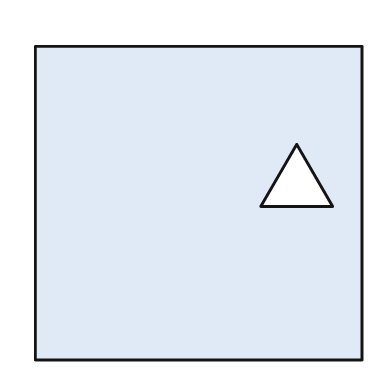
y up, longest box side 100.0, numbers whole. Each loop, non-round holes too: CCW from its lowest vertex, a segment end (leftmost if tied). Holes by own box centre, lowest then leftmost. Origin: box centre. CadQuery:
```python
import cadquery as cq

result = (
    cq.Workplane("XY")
    .moveTo(-50.0, -48.0)
    .lineTo(50.0, -48.0)
    .lineTo(50.0, 48.0)
    .lineTo(-50.0, 48.0)
    .close()
    .moveTo(19.0, -1.0)
    .lineTo(41.0, -1.0)
    .lineTo(30.0, 18.0)
    .close()
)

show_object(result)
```